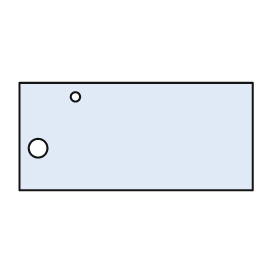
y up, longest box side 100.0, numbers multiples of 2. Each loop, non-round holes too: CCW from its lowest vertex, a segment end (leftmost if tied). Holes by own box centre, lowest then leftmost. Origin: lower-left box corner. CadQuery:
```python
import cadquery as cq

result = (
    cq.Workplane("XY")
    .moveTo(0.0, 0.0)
    .lineTo(100.0, 0.0)
    .lineTo(100.0, 46.0)
    .lineTo(0.0, 46.0)
    .close()
    .moveTo(8.0, 18.0)
    .circle(4.0)
    .moveTo(24.0, 40.0)
    .circle(2.0)
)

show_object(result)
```